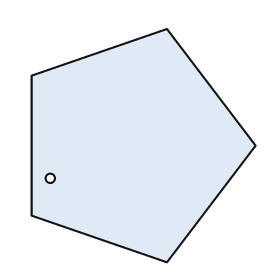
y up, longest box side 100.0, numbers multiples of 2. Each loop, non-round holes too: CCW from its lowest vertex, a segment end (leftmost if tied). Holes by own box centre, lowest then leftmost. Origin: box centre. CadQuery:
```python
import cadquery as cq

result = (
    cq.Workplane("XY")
    .moveTo(10.0, -50.0)
    .lineTo(48.0, 0.0)
    .lineTo(10.0, 50.0)
    .lineTo(-48.0, 30.0)
    .lineTo(-48.0, -30.0)
    .close()
    .moveTo(-40.0, -14.0)
    .circle(2.0)
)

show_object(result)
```